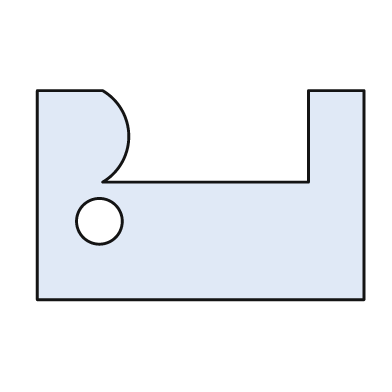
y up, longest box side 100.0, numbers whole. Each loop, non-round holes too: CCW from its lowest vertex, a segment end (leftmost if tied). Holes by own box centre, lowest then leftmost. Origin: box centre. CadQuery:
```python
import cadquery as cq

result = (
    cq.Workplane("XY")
    .moveTo(-50.0, -32.0)
    .lineTo(50.0, -32.0)
    .lineTo(50.0, 32.0)
    .lineTo(33.0, 32.0)
    .lineTo(33.0, 4.0)
    .lineTo(-30.0, 4.0)
    .threePointArc((-22.0, 18.0), (-30.0, 32.0))
    .lineTo(-50.0, 32.0)
    .close()
    .moveTo(-31.0, -8.0)
    .circle(7.0)
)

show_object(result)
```